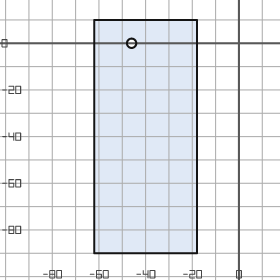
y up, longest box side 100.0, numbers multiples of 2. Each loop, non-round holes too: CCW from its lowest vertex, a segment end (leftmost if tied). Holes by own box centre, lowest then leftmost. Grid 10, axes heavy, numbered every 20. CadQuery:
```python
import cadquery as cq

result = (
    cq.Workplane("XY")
    .moveTo(-62.0, -90.0)
    .lineTo(-18.0, -90.0)
    .lineTo(-18.0, 10.0)
    .lineTo(-62.0, 10.0)
    .close()
    .moveTo(-46.0, 0.0)
    .circle(2.0)
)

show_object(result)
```